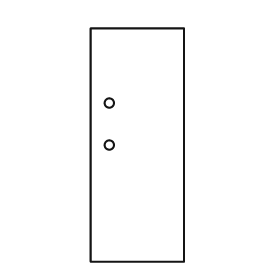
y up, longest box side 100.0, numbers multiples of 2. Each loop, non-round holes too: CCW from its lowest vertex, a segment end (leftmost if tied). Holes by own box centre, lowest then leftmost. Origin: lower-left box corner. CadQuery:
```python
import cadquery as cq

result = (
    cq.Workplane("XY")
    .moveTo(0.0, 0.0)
    .lineTo(40.0, 0.0)
    .lineTo(40.0, 100.0)
    .lineTo(0.0, 100.0)
    .close()
    .moveTo(8.0, 50.0)
    .circle(2.0)
    .moveTo(8.0, 68.0)
    .circle(2.0)
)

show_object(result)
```